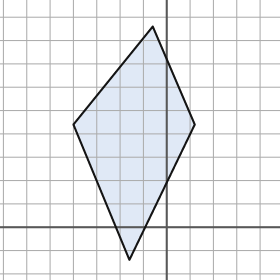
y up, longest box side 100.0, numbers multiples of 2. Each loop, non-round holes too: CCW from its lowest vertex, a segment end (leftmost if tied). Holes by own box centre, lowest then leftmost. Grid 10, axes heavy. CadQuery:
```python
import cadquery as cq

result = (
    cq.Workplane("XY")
    .moveTo(-16.0, -14.0)
    .lineTo(12.0, 44.0)
    .lineTo(-6.0, 86.0)
    .lineTo(-40.0, 44.0)
    .close()
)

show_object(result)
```